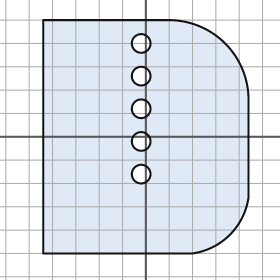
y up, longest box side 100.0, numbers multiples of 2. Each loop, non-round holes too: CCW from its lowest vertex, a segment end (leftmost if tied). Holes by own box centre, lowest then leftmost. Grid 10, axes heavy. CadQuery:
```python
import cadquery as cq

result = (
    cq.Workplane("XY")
    .moveTo(-44.0, -50.0)
    .lineTo(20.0, -50.0)
    .threePointArc((36.0, -42.0), (44.0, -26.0))
    .lineTo(44.0, 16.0)
    .threePointArc((34.0, 40.0), (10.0, 50.0))
    .lineTo(-44.0, 50.0)
    .close()
    .moveTo(-2.0, -16.0)
    .circle(4.0)
    .moveTo(-2.0, -2.0)
    .circle(4.0)
    .moveTo(-2.0, 12.0)
    .circle(4.0)
    .moveTo(-2.0, 26.0)
    .circle(4.0)
    .moveTo(-2.0, 40.0)
    .circle(4.0)
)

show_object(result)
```